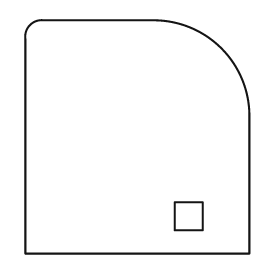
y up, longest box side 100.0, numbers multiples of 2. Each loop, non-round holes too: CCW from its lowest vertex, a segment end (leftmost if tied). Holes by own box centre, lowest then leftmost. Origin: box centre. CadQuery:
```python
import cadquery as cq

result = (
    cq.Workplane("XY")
    .moveTo(-48.0, -50.0)
    .lineTo(48.0, -50.0)
    .lineTo(48.0, 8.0)
    .threePointArc((36.0, 38.0), (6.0, 50.0))
    .lineTo(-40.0, 50.0)
    .threePointArc((-46.0, 48.0), (-48.0, 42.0))
    .close()
    .moveTo(16.0, -40.0)
    .lineTo(28.0, -40.0)
    .lineTo(28.0, -28.0)
    .lineTo(16.0, -28.0)
    .close()
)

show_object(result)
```